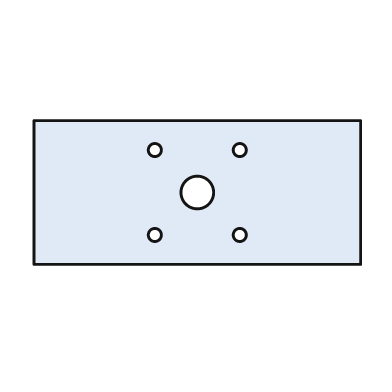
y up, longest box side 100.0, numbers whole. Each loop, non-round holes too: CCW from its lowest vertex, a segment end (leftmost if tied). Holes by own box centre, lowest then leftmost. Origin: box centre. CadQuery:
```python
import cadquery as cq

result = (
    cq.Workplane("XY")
    .moveTo(-50.0, -22.0)
    .lineTo(50.0, -22.0)
    .lineTo(50.0, 22.0)
    .lineTo(-50.0, 22.0)
    .close()
    .moveTo(-13.0, -13.0)
    .circle(2.0)
    .moveTo(13.0, -13.0)
    .circle(2.0)
    .moveTo(0.0, 0.0)
    .circle(5.0)
    .moveTo(-13.0, 13.0)
    .circle(2.0)
    .moveTo(13.0, 13.0)
    .circle(2.0)
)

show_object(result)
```